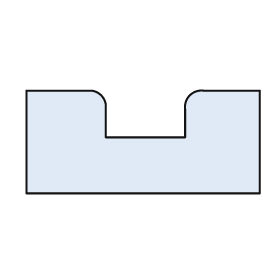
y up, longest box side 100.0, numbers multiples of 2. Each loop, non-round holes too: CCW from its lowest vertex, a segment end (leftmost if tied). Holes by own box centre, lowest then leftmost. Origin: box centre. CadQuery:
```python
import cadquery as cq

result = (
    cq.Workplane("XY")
    .moveTo(-50.0, -22.0)
    .lineTo(50.0, -22.0)
    .lineTo(50.0, 22.0)
    .lineTo(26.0, 22.0)
    .threePointArc((20.0, 20.0), (18.0, 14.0))
    .lineTo(18.0, 2.0)
    .lineTo(-16.0, 2.0)
    .lineTo(-16.0, 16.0)
    .threePointArc((-18.0, 20.0), (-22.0, 22.0))
    .lineTo(-50.0, 22.0)
    .close()
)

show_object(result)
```